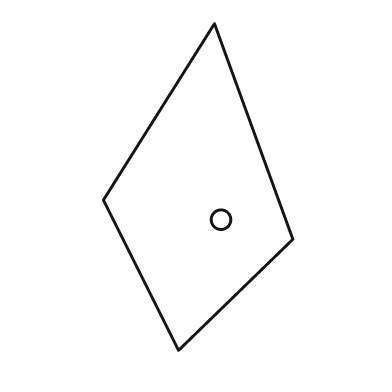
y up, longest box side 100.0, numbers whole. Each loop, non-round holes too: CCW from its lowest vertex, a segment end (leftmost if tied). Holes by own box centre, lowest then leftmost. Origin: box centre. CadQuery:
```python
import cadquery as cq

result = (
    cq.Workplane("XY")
    .moveTo(-6.0, -50.0)
    .lineTo(29.0, -16.0)
    .lineTo(5.0, 50.0)
    .lineTo(-29.0, -4.0)
    .close()
    .moveTo(7.0, -10.0)
    .circle(3.0)
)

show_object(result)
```